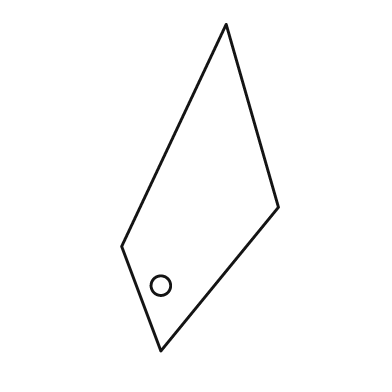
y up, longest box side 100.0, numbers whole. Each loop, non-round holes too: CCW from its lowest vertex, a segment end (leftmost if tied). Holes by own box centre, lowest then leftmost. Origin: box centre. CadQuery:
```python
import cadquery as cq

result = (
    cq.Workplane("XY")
    .moveTo(-12.0, -50.0)
    .lineTo(24.0, -6.0)
    .lineTo(8.0, 50.0)
    .lineTo(-24.0, -18.0)
    .close()
    .moveTo(-12.0, -30.0)
    .circle(3.0)
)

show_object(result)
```